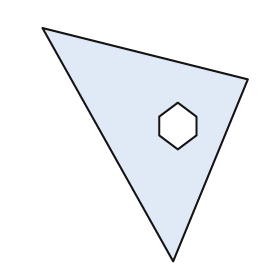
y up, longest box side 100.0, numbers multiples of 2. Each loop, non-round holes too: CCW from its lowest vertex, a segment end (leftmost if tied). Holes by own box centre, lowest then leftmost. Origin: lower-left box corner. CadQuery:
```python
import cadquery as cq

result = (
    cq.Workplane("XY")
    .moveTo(56.0, 0.0)
    .lineTo(88.0, 78.0)
    .lineTo(0.0, 100.0)
    .close()
    .moveTo(58.0, 48.0)
    .lineTo(66.0, 54.0)
    .lineTo(66.0, 62.0)
    .lineTo(58.0, 68.0)
    .lineTo(50.0, 62.0)
    .lineTo(50.0, 54.0)
    .close()
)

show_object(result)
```